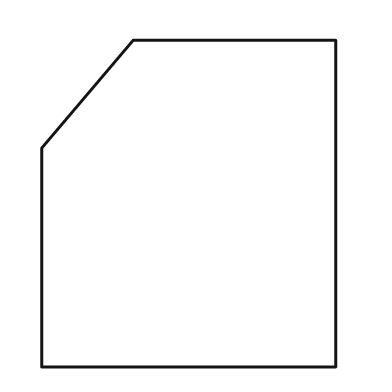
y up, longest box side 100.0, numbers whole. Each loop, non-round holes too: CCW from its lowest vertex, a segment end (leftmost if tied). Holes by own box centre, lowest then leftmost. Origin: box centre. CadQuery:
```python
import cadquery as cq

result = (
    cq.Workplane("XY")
    .moveTo(-45.0, -50.0)
    .lineTo(45.0, -50.0)
    .lineTo(45.0, 50.0)
    .lineTo(-17.0, 50.0)
    .lineTo(-45.0, 17.0)
    .close()
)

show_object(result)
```